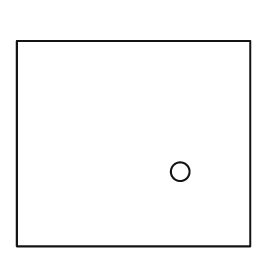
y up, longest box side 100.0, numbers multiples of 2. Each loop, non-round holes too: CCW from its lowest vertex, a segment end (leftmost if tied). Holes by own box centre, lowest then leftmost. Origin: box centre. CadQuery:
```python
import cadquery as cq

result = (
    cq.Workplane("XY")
    .moveTo(-50.0, -44.0)
    .lineTo(50.0, -44.0)
    .lineTo(50.0, 44.0)
    .lineTo(-50.0, 44.0)
    .close()
    .moveTo(20.0, -12.0)
    .circle(4.0)
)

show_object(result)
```